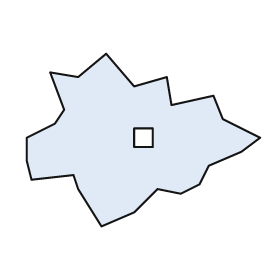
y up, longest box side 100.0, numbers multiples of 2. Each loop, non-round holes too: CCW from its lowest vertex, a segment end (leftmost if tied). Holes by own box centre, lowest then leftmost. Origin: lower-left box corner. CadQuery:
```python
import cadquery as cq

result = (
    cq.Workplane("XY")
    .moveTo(32.0, 0.0)
    .lineTo(46.0, 6.0)
    .lineTo(56.0, 16.0)
    .lineTo(66.0, 14.0)
    .lineTo(74.0, 18.0)
    .lineTo(78.0, 26.0)
    .lineTo(92.0, 32.0)
    .lineTo(100.0, 38.0)
    .lineTo(84.0, 46.0)
    .lineTo(80.0, 56.0)
    .lineTo(62.0, 52.0)
    .lineTo(60.0, 64.0)
    .lineTo(46.0, 60.0)
    .lineTo(34.0, 74.0)
    .lineTo(22.0, 64.0)
    .lineTo(10.0, 66.0)
    .lineTo(16.0, 50.0)
    .lineTo(12.0, 44.0)
    .lineTo(0.0, 38.0)
    .lineTo(0.0, 28.0)
    .lineTo(2.0, 20.0)
    .lineTo(20.0, 22.0)
    .lineTo(22.0, 16.0)
    .close()
    .moveTo(46.0, 34.0)
    .lineTo(54.0, 34.0)
    .lineTo(54.0, 42.0)
    .lineTo(46.0, 42.0)
    .close()
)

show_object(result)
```